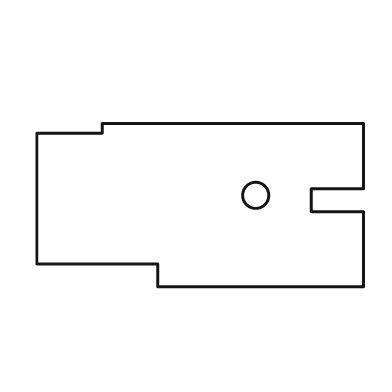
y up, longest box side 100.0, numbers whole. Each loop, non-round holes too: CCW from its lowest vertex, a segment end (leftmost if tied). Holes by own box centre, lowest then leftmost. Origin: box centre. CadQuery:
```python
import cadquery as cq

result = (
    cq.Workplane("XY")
    .moveTo(-13.0, -25.0)
    .lineTo(50.0, -25.0)
    .lineTo(50.0, -2.0)
    .lineTo(34.0, -2.0)
    .lineTo(34.0, 5.0)
    .lineTo(50.0, 5.0)
    .lineTo(50.0, 25.0)
    .lineTo(-30.0, 25.0)
    .lineTo(-30.0, 22.0)
    .lineTo(-50.0, 22.0)
    .lineTo(-50.0, -18.0)
    .lineTo(-13.0, -18.0)
    .close()
    .moveTo(17.0, 3.0)
    .circle(4.0)
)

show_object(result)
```